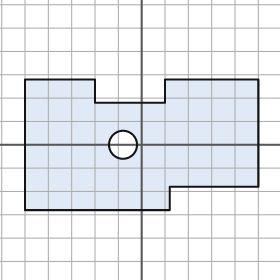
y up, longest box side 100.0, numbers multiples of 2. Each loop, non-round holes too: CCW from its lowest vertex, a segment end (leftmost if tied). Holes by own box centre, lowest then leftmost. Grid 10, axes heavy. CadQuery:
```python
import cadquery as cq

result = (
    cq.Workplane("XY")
    .moveTo(-50.0, -28.0)
    .lineTo(12.0, -28.0)
    .lineTo(12.0, -18.0)
    .lineTo(50.0, -18.0)
    .lineTo(50.0, 28.0)
    .lineTo(10.0, 28.0)
    .lineTo(10.0, 18.0)
    .lineTo(-20.0, 18.0)
    .lineTo(-20.0, 28.0)
    .lineTo(-50.0, 28.0)
    .close()
    .moveTo(-8.0, 0.0)
    .circle(6.0)
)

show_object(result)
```